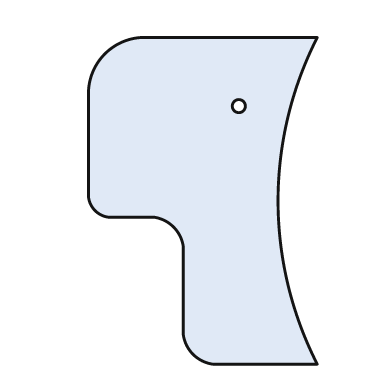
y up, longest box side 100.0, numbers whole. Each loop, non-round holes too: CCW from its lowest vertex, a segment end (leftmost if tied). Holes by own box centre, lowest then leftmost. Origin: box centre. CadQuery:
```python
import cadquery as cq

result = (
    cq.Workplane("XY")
    .moveTo(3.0, -50.0)
    .lineTo(35.0, -50.0)
    .threePointArc((23.0, 0.0), (35.0, 50.0))
    .lineTo(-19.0, 50.0)
    .threePointArc((-30.0, 45.0), (-35.0, 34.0))
    .lineTo(-35.0, 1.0)
    .threePointArc((-33.0, -3.0), (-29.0, -5.0))
    .lineTo(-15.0, -5.0)
    .threePointArc((-9.0, -8.0), (-6.0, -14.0))
    .lineTo(-6.0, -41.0)
    .threePointArc((-3.0, -47.0), (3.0, -50.0))
    .close()
    .moveTo(11.0, 29.0)
    .circle(2.0)
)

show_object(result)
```